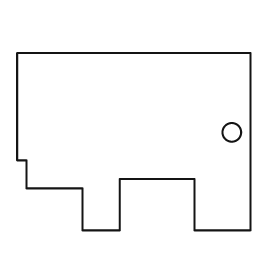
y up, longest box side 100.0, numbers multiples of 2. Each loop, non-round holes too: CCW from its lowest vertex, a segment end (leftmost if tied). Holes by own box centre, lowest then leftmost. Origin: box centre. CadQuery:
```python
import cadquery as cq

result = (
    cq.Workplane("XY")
    .moveTo(-22.0, -38.0)
    .lineTo(-6.0, -38.0)
    .lineTo(-6.0, -16.0)
    .lineTo(26.0, -16.0)
    .lineTo(26.0, -38.0)
    .lineTo(50.0, -38.0)
    .lineTo(50.0, 38.0)
    .lineTo(-50.0, 38.0)
    .lineTo(-50.0, -8.0)
    .lineTo(-46.0, -8.0)
    .lineTo(-46.0, -20.0)
    .lineTo(-22.0, -20.0)
    .close()
    .moveTo(42.0, 4.0)
    .circle(4.0)
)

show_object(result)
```